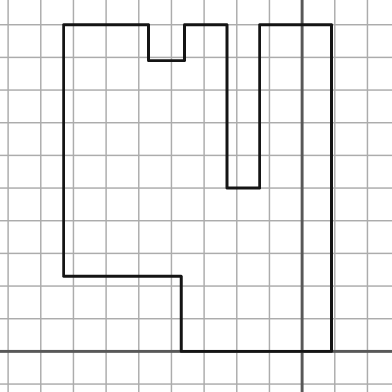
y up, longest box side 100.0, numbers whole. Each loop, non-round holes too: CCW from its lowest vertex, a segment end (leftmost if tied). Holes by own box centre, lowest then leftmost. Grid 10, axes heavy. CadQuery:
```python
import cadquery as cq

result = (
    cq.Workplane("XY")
    .moveTo(-37.0, 0.0)
    .lineTo(9.0, 0.0)
    .lineTo(9.0, 100.0)
    .lineTo(-13.0, 100.0)
    .lineTo(-13.0, 50.0)
    .lineTo(-23.0, 50.0)
    .lineTo(-23.0, 100.0)
    .lineTo(-36.0, 100.0)
    .lineTo(-36.0, 89.0)
    .lineTo(-47.0, 89.0)
    .lineTo(-47.0, 100.0)
    .lineTo(-73.0, 100.0)
    .lineTo(-73.0, 23.0)
    .lineTo(-37.0, 23.0)
    .close()
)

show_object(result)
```